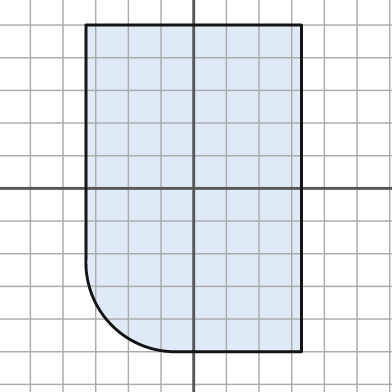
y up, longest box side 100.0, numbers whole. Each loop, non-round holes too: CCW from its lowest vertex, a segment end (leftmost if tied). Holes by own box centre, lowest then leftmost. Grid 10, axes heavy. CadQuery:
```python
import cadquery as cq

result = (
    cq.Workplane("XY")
    .moveTo(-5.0, -50.0)
    .lineTo(33.0, -50.0)
    .lineTo(33.0, 50.0)
    .lineTo(-33.0, 50.0)
    .lineTo(-33.0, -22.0)
    .threePointArc((-25.0, -42.0), (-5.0, -50.0))
    .close()
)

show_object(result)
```